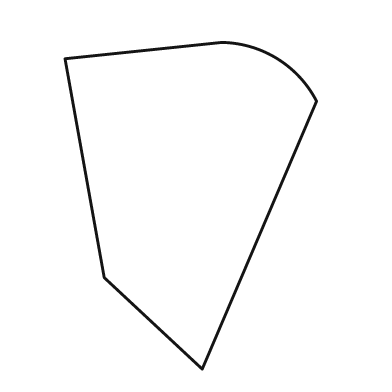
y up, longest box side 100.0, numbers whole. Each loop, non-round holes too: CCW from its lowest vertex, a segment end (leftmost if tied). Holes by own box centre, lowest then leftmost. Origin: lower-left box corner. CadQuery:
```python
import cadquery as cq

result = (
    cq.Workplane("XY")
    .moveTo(42.0, 0.0)
    .lineTo(77.0, 82.0)
    .threePointArc((65.0, 95.0), (48.0, 100.0))
    .lineTo(0.0, 95.0)
    .lineTo(12.0, 28.0)
    .close()
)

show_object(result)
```